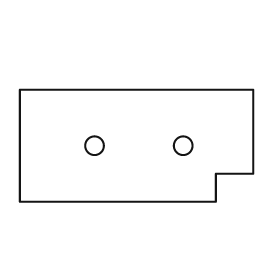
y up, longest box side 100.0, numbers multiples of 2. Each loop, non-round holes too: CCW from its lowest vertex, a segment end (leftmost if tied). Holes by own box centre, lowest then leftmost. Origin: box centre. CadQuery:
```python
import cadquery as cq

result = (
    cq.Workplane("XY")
    .moveTo(-50.0, -24.0)
    .lineTo(34.0, -24.0)
    .lineTo(34.0, -12.0)
    .lineTo(50.0, -12.0)
    .lineTo(50.0, 24.0)
    .lineTo(-50.0, 24.0)
    .close()
    .moveTo(-18.0, 0.0)
    .circle(4.0)
    .moveTo(20.0, 0.0)
    .circle(4.0)
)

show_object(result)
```